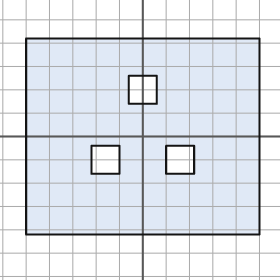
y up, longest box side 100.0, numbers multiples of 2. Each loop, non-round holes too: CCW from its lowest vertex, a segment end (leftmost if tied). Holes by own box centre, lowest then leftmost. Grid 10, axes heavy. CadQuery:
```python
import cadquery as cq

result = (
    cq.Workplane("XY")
    .moveTo(-50.0, -42.0)
    .lineTo(50.0, -42.0)
    .lineTo(50.0, 42.0)
    .lineTo(-50.0, 42.0)
    .close()
    .moveTo(-22.0, -16.0)
    .lineTo(-10.0, -16.0)
    .lineTo(-10.0, -4.0)
    .lineTo(-22.0, -4.0)
    .close()
    .moveTo(10.0, -16.0)
    .lineTo(22.0, -16.0)
    .lineTo(22.0, -4.0)
    .lineTo(10.0, -4.0)
    .close()
    .moveTo(-6.0, 14.0)
    .lineTo(6.0, 14.0)
    .lineTo(6.0, 26.0)
    .lineTo(-6.0, 26.0)
    .close()
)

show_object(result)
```